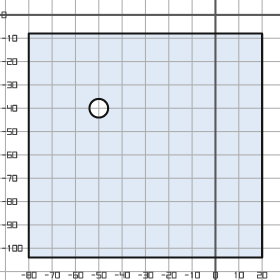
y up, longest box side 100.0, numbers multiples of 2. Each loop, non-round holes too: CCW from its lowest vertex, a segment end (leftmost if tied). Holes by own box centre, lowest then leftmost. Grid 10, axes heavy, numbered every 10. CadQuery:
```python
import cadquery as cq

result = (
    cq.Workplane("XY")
    .moveTo(-80.0, -104.0)
    .lineTo(20.0, -104.0)
    .lineTo(20.0, -8.0)
    .lineTo(-80.0, -8.0)
    .close()
    .moveTo(-50.0, -40.0)
    .circle(4.0)
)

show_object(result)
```